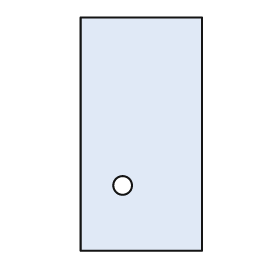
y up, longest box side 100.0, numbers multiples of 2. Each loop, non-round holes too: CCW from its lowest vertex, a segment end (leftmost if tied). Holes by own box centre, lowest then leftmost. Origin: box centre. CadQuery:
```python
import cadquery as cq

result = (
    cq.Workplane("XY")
    .moveTo(-26.0, -50.0)
    .lineTo(26.0, -50.0)
    .lineTo(26.0, 50.0)
    .lineTo(-26.0, 50.0)
    .close()
    .moveTo(-8.0, -22.0)
    .circle(4.0)
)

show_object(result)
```